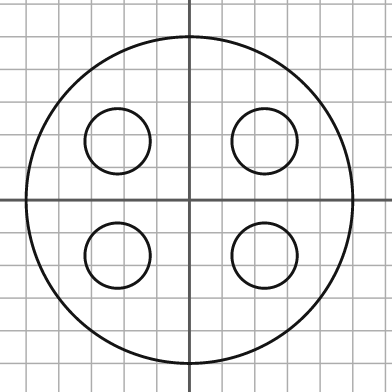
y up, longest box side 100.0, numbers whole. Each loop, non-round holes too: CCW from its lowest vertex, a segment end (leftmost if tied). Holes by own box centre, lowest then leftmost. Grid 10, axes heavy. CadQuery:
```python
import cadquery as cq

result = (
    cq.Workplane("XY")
    .moveTo(0.0, 0.0)
    .circle(50.0)
    .moveTo(-22.0, -17.0)
    .circle(10.0)
    .moveTo(23.0, -17.0)
    .circle(10.0)
    .moveTo(-22.0, 18.0)
    .circle(10.0)
    .moveTo(23.0, 18.0)
    .circle(10.0)
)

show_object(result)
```